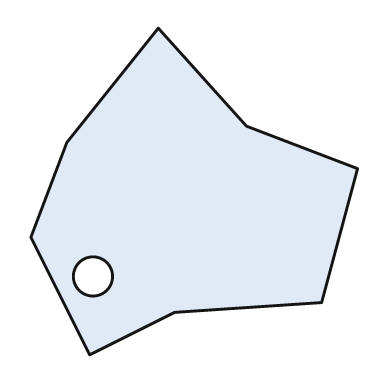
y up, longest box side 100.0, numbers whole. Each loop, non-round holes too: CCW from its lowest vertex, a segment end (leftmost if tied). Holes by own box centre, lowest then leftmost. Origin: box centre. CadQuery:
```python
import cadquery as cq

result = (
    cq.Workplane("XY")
    .moveTo(-32.0, -50.0)
    .lineTo(-6.0, -37.0)
    .lineTo(39.0, -34.0)
    .lineTo(50.0, 7.0)
    .lineTo(16.0, 20.0)
    .lineTo(-11.0, 50.0)
    .lineTo(-39.0, 15.0)
    .lineTo(-50.0, -14.0)
    .close()
    .moveTo(-31.0, -26.0)
    .circle(6.0)
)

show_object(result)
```